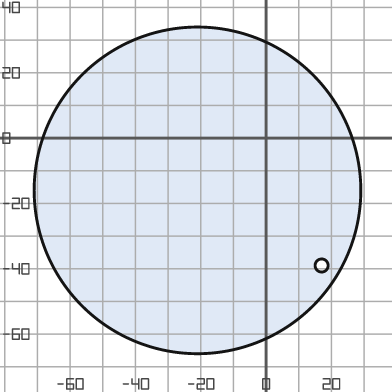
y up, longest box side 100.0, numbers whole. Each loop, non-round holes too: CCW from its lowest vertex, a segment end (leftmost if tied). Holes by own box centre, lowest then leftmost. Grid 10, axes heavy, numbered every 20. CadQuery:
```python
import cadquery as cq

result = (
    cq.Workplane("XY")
    .moveTo(-21.0, -16.0)
    .circle(50.0)
    .moveTo(17.0, -39.0)
    .circle(2.0)
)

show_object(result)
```